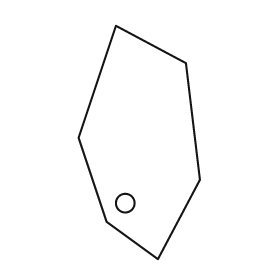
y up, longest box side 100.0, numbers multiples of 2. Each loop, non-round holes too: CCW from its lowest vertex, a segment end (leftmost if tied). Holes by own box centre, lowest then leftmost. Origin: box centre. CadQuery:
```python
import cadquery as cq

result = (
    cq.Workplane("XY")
    .moveTo(8.0, -50.0)
    .lineTo(26.0, -16.0)
    .lineTo(20.0, 34.0)
    .lineTo(-10.0, 50.0)
    .lineTo(-26.0, 2.0)
    .lineTo(-14.0, -34.0)
    .close()
    .moveTo(-6.0, -26.0)
    .circle(4.0)
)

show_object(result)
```